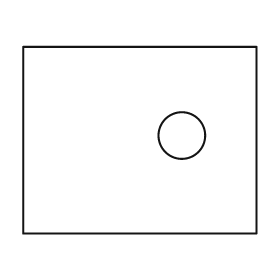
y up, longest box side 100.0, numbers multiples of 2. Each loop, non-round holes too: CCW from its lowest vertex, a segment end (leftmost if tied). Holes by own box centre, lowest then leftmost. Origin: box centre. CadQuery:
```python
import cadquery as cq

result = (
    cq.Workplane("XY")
    .moveTo(-50.0, -40.0)
    .lineTo(50.0, -40.0)
    .lineTo(50.0, 40.0)
    .lineTo(-50.0, 40.0)
    .close()
    .moveTo(18.0, 2.0)
    .circle(10.0)
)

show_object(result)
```